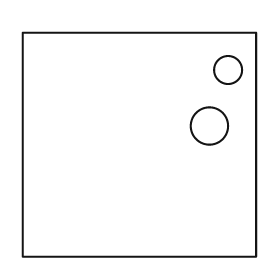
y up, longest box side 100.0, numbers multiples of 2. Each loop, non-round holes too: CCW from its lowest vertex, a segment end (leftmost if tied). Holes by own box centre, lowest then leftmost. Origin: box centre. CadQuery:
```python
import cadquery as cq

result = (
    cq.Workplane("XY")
    .moveTo(-50.0, -48.0)
    .lineTo(50.0, -48.0)
    .lineTo(50.0, 48.0)
    .lineTo(-50.0, 48.0)
    .close()
    .moveTo(30.0, 8.0)
    .circle(8.0)
    .moveTo(38.0, 32.0)
    .circle(6.0)
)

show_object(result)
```